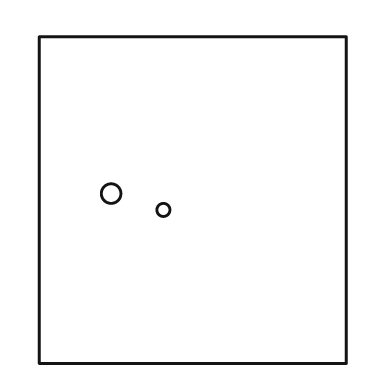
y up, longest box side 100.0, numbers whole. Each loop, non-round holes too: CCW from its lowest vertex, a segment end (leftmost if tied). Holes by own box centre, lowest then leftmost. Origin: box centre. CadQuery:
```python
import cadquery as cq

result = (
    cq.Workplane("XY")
    .moveTo(-47.0, -50.0)
    .lineTo(47.0, -50.0)
    .lineTo(47.0, 50.0)
    .lineTo(-47.0, 50.0)
    .close()
    .moveTo(-9.0, -3.0)
    .circle(2.0)
    .moveTo(-25.0, 2.0)
    .circle(3.0)
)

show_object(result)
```